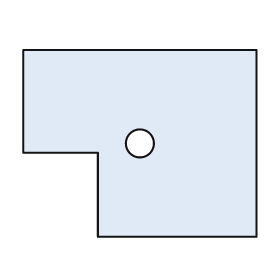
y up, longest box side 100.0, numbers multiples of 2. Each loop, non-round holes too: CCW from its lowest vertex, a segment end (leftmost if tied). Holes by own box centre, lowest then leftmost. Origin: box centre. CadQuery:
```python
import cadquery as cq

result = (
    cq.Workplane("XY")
    .moveTo(-18.0, -40.0)
    .lineTo(50.0, -40.0)
    .lineTo(50.0, 40.0)
    .lineTo(-50.0, 40.0)
    .lineTo(-50.0, -4.0)
    .lineTo(-18.0, -4.0)
    .close()
    .moveTo(0.0, 0.0)
    .circle(6.0)
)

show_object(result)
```